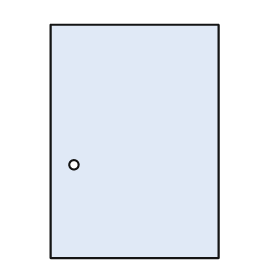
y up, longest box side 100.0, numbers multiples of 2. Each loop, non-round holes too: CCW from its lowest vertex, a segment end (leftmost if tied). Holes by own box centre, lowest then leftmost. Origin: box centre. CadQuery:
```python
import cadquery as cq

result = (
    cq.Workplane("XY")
    .moveTo(-36.0, -50.0)
    .lineTo(36.0, -50.0)
    .lineTo(36.0, 50.0)
    .lineTo(-36.0, 50.0)
    .close()
    .moveTo(-26.0, -10.0)
    .circle(2.0)
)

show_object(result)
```